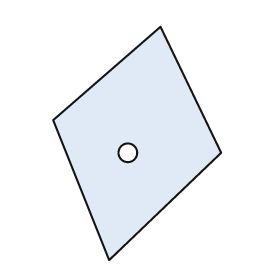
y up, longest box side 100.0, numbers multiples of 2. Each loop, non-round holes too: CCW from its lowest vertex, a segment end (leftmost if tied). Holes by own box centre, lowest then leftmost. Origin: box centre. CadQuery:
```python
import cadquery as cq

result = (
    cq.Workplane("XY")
    .moveTo(-12.0, -50.0)
    .lineTo(36.0, -4.0)
    .lineTo(10.0, 50.0)
    .lineTo(-36.0, 10.0)
    .close()
    .moveTo(-4.0, -4.0)
    .circle(4.0)
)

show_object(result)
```